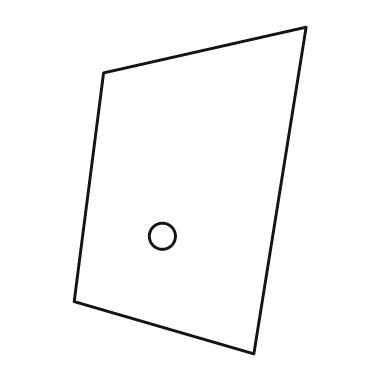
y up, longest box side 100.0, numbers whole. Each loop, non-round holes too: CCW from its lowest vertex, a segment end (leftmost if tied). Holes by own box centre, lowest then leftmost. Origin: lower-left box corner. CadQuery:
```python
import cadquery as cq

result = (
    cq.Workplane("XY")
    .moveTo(55.0, 0.0)
    .lineTo(71.0, 100.0)
    .lineTo(9.0, 86.0)
    .lineTo(0.0, 16.0)
    .close()
    .moveTo(27.0, 36.0)
    .circle(4.0)
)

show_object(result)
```